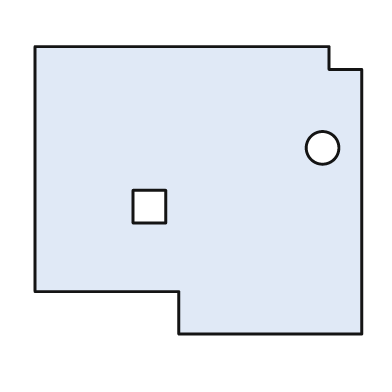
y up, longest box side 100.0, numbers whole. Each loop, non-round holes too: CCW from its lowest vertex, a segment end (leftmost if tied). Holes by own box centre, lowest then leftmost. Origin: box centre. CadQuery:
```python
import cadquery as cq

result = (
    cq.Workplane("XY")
    .moveTo(-6.0, -44.0)
    .lineTo(50.0, -44.0)
    .lineTo(50.0, 37.0)
    .lineTo(40.0, 37.0)
    .lineTo(40.0, 44.0)
    .lineTo(-50.0, 44.0)
    .lineTo(-50.0, -31.0)
    .lineTo(-6.0, -31.0)
    .close()
    .moveTo(-20.0, -10.0)
    .lineTo(-10.0, -10.0)
    .lineTo(-10.0, 0.0)
    .lineTo(-20.0, 0.0)
    .close()
    .moveTo(38.0, 13.0)
    .circle(5.0)
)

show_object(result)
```